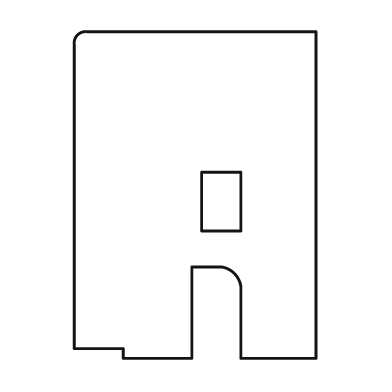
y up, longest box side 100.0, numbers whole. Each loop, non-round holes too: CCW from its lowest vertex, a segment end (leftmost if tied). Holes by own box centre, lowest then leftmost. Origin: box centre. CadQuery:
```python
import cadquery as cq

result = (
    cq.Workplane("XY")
    .moveTo(-22.0, -50.0)
    .lineTo(-1.0, -50.0)
    .lineTo(-1.0, -22.0)
    .lineTo(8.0, -22.0)
    .threePointArc((12.0, -24.0), (14.0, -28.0))
    .lineTo(14.0, -50.0)
    .lineTo(37.0, -50.0)
    .lineTo(37.0, 50.0)
    .lineTo(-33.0, 50.0)
    .threePointArc((-36.0, 49.0), (-37.0, 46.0))
    .lineTo(-37.0, -47.0)
    .lineTo(-22.0, -47.0)
    .close()
    .moveTo(2.0, -11.0)
    .lineTo(14.0, -11.0)
    .lineTo(14.0, 7.0)
    .lineTo(2.0, 7.0)
    .close()
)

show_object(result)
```